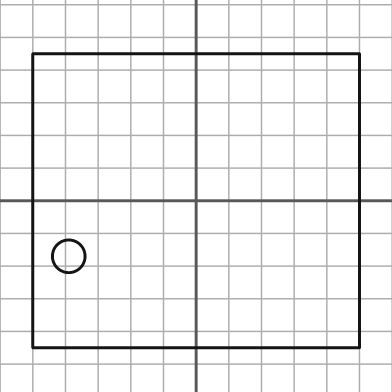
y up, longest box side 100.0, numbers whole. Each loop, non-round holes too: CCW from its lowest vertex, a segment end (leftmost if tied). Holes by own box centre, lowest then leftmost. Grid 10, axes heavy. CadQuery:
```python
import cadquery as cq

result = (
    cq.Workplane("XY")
    .moveTo(-50.0, -45.0)
    .lineTo(50.0, -45.0)
    .lineTo(50.0, 45.0)
    .lineTo(-50.0, 45.0)
    .close()
    .moveTo(-39.0, -17.0)
    .circle(5.0)
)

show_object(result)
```